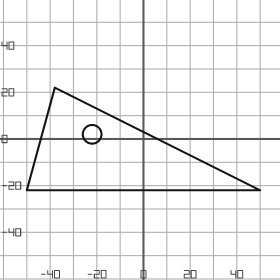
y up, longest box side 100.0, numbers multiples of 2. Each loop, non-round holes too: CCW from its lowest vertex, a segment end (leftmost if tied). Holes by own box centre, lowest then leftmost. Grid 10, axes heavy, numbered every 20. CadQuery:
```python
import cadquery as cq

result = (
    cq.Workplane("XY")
    .moveTo(-50.0, -22.0)
    .lineTo(50.0, -22.0)
    .lineTo(-38.0, 22.0)
    .close()
    .moveTo(-22.0, 2.0)
    .circle(4.0)
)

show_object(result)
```